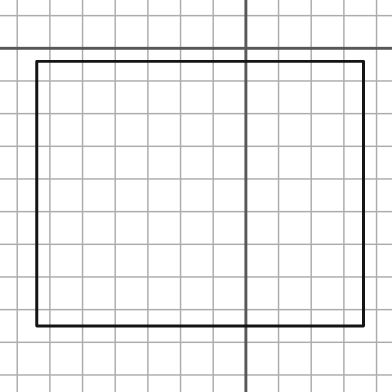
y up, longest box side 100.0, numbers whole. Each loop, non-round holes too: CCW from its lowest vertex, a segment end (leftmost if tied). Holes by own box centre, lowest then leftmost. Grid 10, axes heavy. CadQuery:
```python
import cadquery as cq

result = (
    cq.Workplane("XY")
    .moveTo(-64.0, -85.0)
    .lineTo(36.0, -85.0)
    .lineTo(36.0, -4.0)
    .lineTo(-64.0, -4.0)
    .close()
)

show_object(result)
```